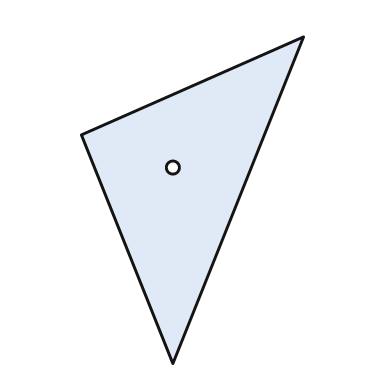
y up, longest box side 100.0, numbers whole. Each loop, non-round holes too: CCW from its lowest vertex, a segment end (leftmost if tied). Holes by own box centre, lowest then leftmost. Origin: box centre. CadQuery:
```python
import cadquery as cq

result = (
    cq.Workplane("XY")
    .moveTo(-6.0, -50.0)
    .lineTo(34.0, 50.0)
    .lineTo(-34.0, 20.0)
    .close()
    .moveTo(-6.0, 10.0)
    .circle(2.0)
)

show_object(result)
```